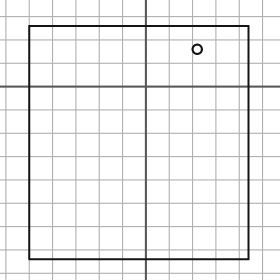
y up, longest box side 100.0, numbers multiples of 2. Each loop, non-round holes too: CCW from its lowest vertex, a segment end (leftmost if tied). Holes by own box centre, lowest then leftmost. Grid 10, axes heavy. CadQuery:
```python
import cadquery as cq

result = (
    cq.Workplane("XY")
    .moveTo(-50.0, -74.0)
    .lineTo(44.0, -74.0)
    .lineTo(44.0, 26.0)
    .lineTo(-50.0, 26.0)
    .close()
    .moveTo(22.0, 16.0)
    .circle(2.0)
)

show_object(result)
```